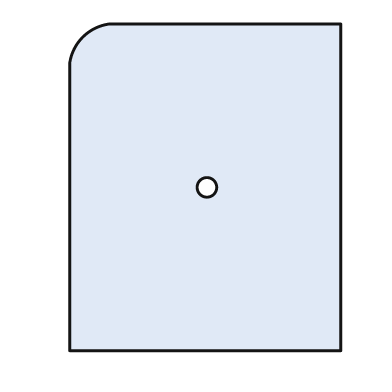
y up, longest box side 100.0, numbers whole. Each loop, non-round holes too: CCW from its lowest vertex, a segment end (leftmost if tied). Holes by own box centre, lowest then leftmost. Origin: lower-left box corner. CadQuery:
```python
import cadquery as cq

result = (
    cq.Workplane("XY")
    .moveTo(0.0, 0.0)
    .lineTo(83.0, 0.0)
    .lineTo(83.0, 100.0)
    .lineTo(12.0, 100.0)
    .threePointArc((4.0, 96.0), (0.0, 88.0))
    .close()
    .moveTo(42.0, 50.0)
    .circle(3.0)
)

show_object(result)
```